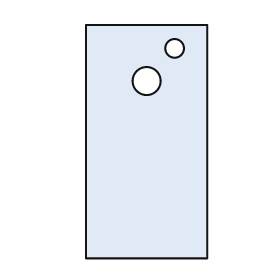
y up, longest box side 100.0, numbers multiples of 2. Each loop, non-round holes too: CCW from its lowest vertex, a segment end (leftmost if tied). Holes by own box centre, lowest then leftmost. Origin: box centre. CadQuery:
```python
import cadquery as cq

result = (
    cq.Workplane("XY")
    .moveTo(-26.0, -50.0)
    .lineTo(26.0, -50.0)
    .lineTo(26.0, 50.0)
    .lineTo(-26.0, 50.0)
    .close()
    .moveTo(0.0, 26.0)
    .circle(6.0)
    .moveTo(12.0, 40.0)
    .circle(4.0)
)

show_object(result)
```